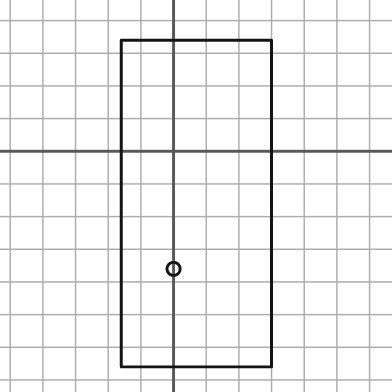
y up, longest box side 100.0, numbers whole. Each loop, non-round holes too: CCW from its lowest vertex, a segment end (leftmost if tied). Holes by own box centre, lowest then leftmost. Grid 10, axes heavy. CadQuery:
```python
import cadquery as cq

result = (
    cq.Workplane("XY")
    .moveTo(-16.0, -66.0)
    .lineTo(30.0, -66.0)
    .lineTo(30.0, 34.0)
    .lineTo(-16.0, 34.0)
    .close()
    .moveTo(0.0, -36.0)
    .circle(2.0)
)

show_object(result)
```